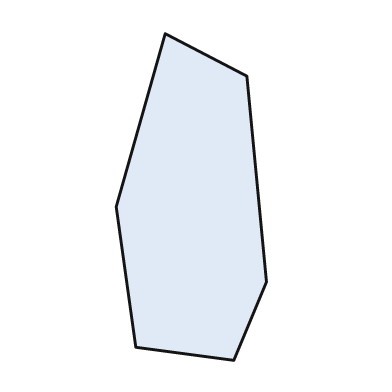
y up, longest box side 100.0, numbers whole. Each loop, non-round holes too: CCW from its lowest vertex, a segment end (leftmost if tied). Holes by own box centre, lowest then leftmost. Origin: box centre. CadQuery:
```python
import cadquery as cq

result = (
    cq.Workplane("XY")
    .moveTo(13.0, -50.0)
    .lineTo(23.0, -26.0)
    .lineTo(17.0, 37.0)
    .lineTo(-8.0, 50.0)
    .lineTo(-23.0, -3.0)
    .lineTo(-17.0, -46.0)
    .close()
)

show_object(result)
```